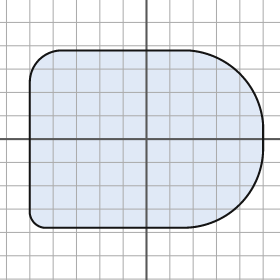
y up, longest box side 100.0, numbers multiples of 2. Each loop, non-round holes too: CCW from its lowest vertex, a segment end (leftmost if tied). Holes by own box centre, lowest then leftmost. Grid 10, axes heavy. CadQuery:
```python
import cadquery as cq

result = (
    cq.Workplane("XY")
    .moveTo(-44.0, -38.0)
    .lineTo(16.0, -38.0)
    .threePointArc((40.0, -28.0), (50.0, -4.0))
    .lineTo(50.0, 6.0)
    .threePointArc((40.0, 28.0), (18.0, 38.0))
    .lineTo(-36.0, 38.0)
    .threePointArc((-46.0, 34.0), (-50.0, 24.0))
    .lineTo(-50.0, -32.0)
    .threePointArc((-48.0, -36.0), (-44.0, -38.0))
    .close()
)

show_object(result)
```